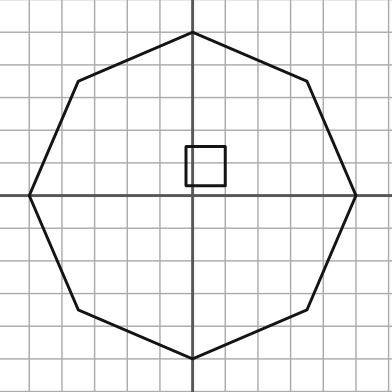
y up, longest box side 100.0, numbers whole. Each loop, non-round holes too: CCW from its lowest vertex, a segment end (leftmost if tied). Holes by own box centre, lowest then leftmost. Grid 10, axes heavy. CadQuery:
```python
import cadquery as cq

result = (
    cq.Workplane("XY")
    .moveTo(0.0, -50.0)
    .lineTo(35.0, -35.0)
    .lineTo(50.0, 0.0)
    .lineTo(35.0, 35.0)
    .lineTo(0.0, 50.0)
    .lineTo(-35.0, 35.0)
    .lineTo(-50.0, 0.0)
    .lineTo(-35.0, -35.0)
    .close()
    .moveTo(-2.0, 3.0)
    .lineTo(10.0, 3.0)
    .lineTo(10.0, 15.0)
    .lineTo(-2.0, 15.0)
    .close()
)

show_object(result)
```